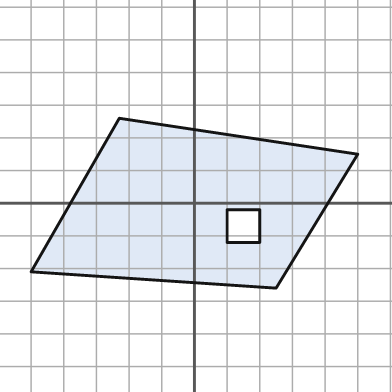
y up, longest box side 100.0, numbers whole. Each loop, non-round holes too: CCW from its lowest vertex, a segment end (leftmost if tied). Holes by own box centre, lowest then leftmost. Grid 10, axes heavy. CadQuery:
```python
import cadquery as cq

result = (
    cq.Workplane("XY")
    .moveTo(25.0, -26.0)
    .lineTo(50.0, 15.0)
    .lineTo(-23.0, 26.0)
    .lineTo(-50.0, -21.0)
    .close()
    .moveTo(10.0, -12.0)
    .lineTo(20.0, -12.0)
    .lineTo(20.0, -2.0)
    .lineTo(10.0, -2.0)
    .close()
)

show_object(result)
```